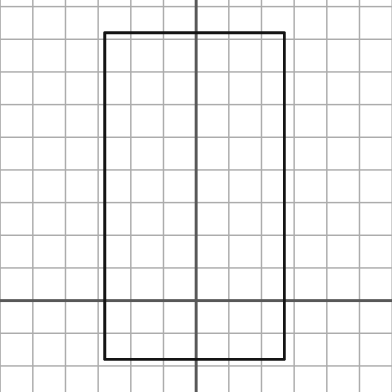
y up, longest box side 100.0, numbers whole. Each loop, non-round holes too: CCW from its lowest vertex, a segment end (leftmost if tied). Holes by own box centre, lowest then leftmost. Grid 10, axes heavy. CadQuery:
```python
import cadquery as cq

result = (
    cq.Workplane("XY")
    .moveTo(-28.0, -18.0)
    .lineTo(27.0, -18.0)
    .lineTo(27.0, 82.0)
    .lineTo(-28.0, 82.0)
    .close()
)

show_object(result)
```